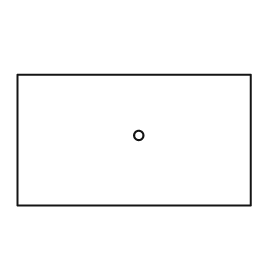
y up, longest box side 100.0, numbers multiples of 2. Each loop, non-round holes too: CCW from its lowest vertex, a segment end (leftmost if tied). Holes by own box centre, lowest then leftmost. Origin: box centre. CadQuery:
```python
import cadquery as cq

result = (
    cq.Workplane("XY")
    .moveTo(-50.0, -28.0)
    .lineTo(50.0, -28.0)
    .lineTo(50.0, 28.0)
    .lineTo(-50.0, 28.0)
    .close()
    .moveTo(2.0, 2.0)
    .circle(2.0)
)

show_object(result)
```